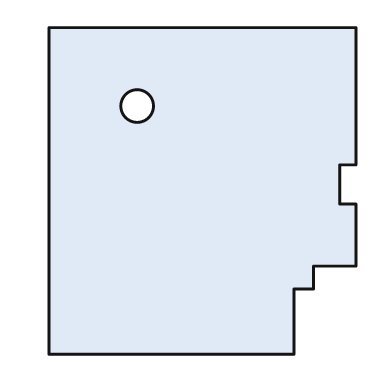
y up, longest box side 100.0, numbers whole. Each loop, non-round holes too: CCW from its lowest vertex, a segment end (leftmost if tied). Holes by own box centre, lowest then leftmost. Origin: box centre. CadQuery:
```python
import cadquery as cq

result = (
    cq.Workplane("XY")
    .moveTo(-47.0, -50.0)
    .lineTo(28.0, -50.0)
    .lineTo(28.0, -30.0)
    .lineTo(34.0, -30.0)
    .lineTo(34.0, -23.0)
    .lineTo(47.0, -23.0)
    .lineTo(47.0, -4.0)
    .lineTo(42.0, -4.0)
    .lineTo(42.0, 8.0)
    .lineTo(47.0, 8.0)
    .lineTo(47.0, 50.0)
    .lineTo(-47.0, 50.0)
    .close()
    .moveTo(-20.0, 26.0)
    .circle(5.0)
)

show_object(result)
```